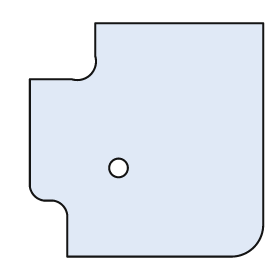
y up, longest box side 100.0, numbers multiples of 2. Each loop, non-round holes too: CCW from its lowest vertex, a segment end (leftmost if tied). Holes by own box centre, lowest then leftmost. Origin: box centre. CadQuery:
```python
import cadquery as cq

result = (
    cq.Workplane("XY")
    .moveTo(-34.0, -50.0)
    .lineTo(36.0, -50.0)
    .threePointArc((46.0, -46.0), (50.0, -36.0))
    .lineTo(50.0, 50.0)
    .lineTo(-22.0, 50.0)
    .lineTo(-22.0, 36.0)
    .threePointArc((-24.0, 28.0), (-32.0, 26.0))
    .lineTo(-50.0, 26.0)
    .lineTo(-50.0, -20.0)
    .threePointArc((-48.0, -24.0), (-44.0, -26.0))
    .lineTo(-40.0, -26.0)
    .threePointArc((-36.0, -28.0), (-34.0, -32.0))
    .close()
    .moveTo(-12.0, -12.0)
    .circle(4.0)
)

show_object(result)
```